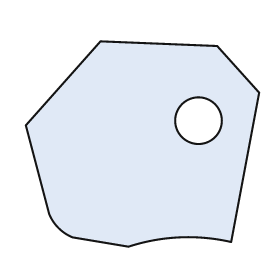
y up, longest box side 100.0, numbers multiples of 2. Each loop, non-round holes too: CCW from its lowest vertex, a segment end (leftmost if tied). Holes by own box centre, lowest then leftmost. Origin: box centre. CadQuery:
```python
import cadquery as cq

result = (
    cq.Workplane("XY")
    .moveTo(-6.0, -44.0)
    .threePointArc((16.0, -40.0), (38.0, -42.0))
    .lineTo(50.0, 22.0)
    .lineTo(32.0, 42.0)
    .lineTo(-18.0, 44.0)
    .lineTo(-50.0, 8.0)
    .lineTo(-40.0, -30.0)
    .threePointArc((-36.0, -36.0), (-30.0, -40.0))
    .close()
    .moveTo(24.0, 10.0)
    .circle(10.0)
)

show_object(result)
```